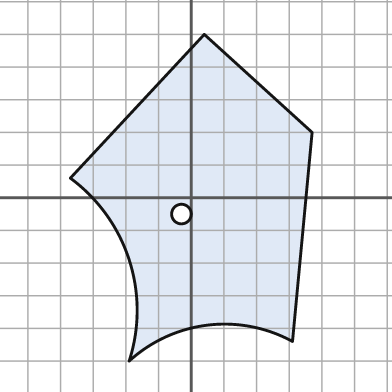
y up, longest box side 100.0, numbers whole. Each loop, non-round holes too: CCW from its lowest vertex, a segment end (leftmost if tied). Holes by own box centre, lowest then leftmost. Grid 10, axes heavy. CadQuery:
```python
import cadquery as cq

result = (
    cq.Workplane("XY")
    .moveTo(-19.0, -50.0)
    .threePointArc((5.0, -39.0), (31.0, -44.0))
    .lineTo(37.0, 20.0)
    .lineTo(4.0, 50.0)
    .lineTo(-37.0, 6.0)
    .threePointArc((-19.0, -19.0), (-19.0, -50.0))
    .close()
    .moveTo(-3.0, -5.0)
    .circle(3.0)
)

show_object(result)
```